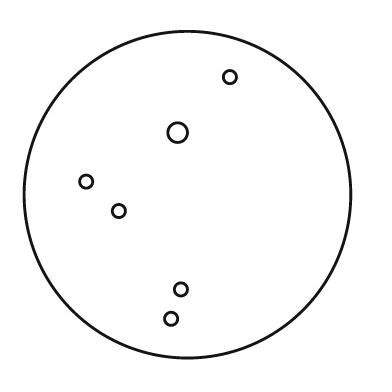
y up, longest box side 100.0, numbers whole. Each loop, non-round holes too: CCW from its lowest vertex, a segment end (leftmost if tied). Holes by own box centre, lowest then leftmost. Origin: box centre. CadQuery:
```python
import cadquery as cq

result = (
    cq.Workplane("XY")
    .moveTo(0.0, 0.0)
    .circle(50.0)
    .moveTo(-5.0, -38.0)
    .circle(2.0)
    .moveTo(-2.0, -29.0)
    .circle(2.0)
    .moveTo(-21.0, -5.0)
    .circle(2.0)
    .moveTo(-31.0, 4.0)
    .circle(2.0)
    .moveTo(-3.0, 19.0)
    .circle(3.0)
    .moveTo(13.0, 36.0)
    .circle(2.0)
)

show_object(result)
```